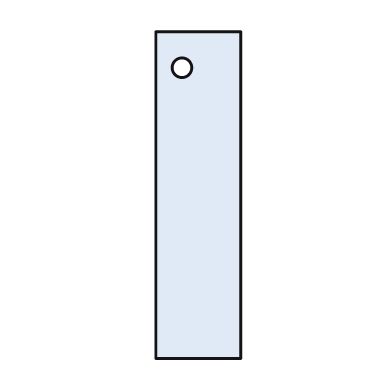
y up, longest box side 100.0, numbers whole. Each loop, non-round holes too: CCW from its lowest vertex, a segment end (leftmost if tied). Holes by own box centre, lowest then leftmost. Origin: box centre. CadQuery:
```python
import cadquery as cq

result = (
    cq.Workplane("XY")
    .moveTo(-13.0, -50.0)
    .lineTo(13.0, -50.0)
    .lineTo(13.0, 50.0)
    .lineTo(-13.0, 50.0)
    .close()
    .moveTo(-5.0, 39.0)
    .circle(3.0)
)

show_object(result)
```